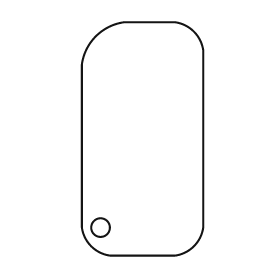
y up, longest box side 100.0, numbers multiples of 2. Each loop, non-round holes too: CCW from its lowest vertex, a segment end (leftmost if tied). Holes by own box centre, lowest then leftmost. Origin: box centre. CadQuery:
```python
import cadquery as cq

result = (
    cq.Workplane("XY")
    .moveTo(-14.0, -50.0)
    .lineTo(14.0, -50.0)
    .threePointArc((22.0, -46.0), (26.0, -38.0))
    .lineTo(26.0, 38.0)
    .threePointArc((22.0, 46.0), (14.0, 50.0))
    .lineTo(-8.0, 50.0)
    .threePointArc((-20.0, 44.0), (-26.0, 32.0))
    .lineTo(-26.0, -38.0)
    .threePointArc((-22.0, -46.0), (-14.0, -50.0))
    .close()
    .moveTo(-18.0, -38.0)
    .circle(4.0)
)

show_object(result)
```